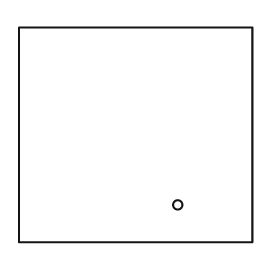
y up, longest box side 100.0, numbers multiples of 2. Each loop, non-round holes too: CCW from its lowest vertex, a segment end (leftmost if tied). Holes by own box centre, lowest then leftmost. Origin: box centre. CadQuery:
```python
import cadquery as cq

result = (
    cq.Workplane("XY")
    .moveTo(-50.0, -46.0)
    .lineTo(50.0, -46.0)
    .lineTo(50.0, 46.0)
    .lineTo(-50.0, 46.0)
    .close()
    .moveTo(18.0, -30.0)
    .circle(2.0)
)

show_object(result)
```